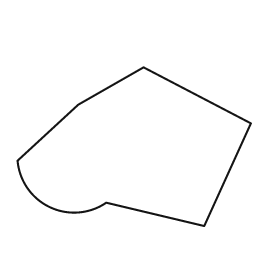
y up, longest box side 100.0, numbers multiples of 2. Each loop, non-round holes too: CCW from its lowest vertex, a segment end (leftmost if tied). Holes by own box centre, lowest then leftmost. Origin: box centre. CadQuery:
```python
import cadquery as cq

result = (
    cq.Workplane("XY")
    .moveTo(30.0, -34.0)
    .lineTo(50.0, 10.0)
    .lineTo(4.0, 34.0)
    .lineTo(-24.0, 18.0)
    .lineTo(-50.0, -6.0)
    .threePointArc((-36.0, -26.0), (-12.0, -24.0))
    .close()
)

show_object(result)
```